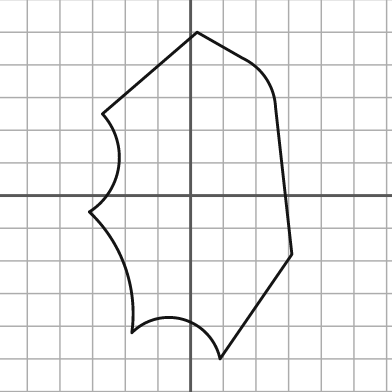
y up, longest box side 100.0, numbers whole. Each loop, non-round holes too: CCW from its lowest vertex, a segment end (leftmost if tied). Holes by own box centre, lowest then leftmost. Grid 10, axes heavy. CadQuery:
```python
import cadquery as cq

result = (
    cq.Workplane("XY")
    .moveTo(9.0, -50.0)
    .lineTo(31.0, -18.0)
    .lineTo(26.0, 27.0)
    .threePointArc((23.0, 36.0), (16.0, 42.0))
    .lineTo(2.0, 50.0)
    .lineTo(-27.0, 25.0)
    .threePointArc((-22.0, 9.0), (-31.0, -5.0))
    .threePointArc((-20.0, -22.0), (-18.0, -42.0))
    .threePointArc((-2.0, -38.0), (9.0, -50.0))
    .close()
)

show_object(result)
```